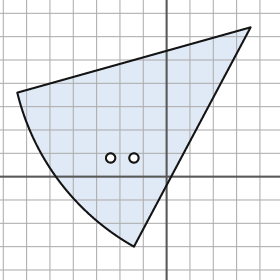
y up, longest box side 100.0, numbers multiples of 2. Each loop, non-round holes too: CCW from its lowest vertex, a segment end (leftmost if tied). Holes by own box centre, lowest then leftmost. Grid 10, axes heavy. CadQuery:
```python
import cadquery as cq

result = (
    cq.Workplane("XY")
    .moveTo(-14.0, -30.0)
    .lineTo(36.0, 64.0)
    .lineTo(-64.0, 36.0)
    .threePointArc((-46.0, -2.0), (-14.0, -30.0))
    .close()
    .moveTo(-24.0, 8.0)
    .circle(2.0)
    .moveTo(-14.0, 8.0)
    .circle(2.0)
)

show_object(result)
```